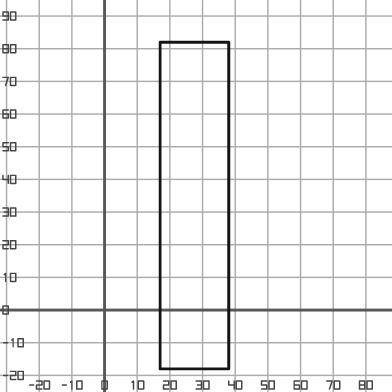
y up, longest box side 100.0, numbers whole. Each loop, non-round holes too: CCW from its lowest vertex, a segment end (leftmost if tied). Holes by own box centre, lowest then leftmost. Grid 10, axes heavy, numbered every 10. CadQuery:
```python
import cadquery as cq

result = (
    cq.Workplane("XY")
    .moveTo(17.0, -18.0)
    .lineTo(38.0, -18.0)
    .lineTo(38.0, 82.0)
    .lineTo(17.0, 82.0)
    .close()
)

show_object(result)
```